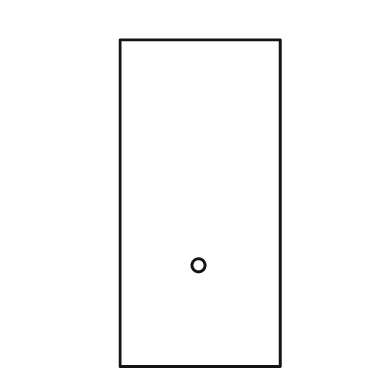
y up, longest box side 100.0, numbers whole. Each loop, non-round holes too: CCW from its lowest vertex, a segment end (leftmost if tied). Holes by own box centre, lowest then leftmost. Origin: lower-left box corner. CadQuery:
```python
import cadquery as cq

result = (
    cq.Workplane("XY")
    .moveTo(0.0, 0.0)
    .lineTo(49.0, 0.0)
    .lineTo(49.0, 100.0)
    .lineTo(0.0, 100.0)
    .close()
    .moveTo(24.0, 31.0)
    .circle(2.0)
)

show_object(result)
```